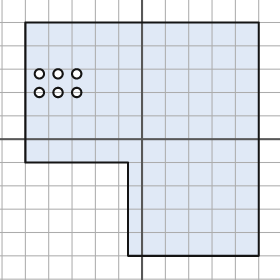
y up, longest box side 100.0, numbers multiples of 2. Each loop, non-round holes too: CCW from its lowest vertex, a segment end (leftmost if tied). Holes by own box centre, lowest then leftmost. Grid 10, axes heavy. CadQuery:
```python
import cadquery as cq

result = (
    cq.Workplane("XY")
    .moveTo(-6.0, -50.0)
    .lineTo(50.0, -50.0)
    .lineTo(50.0, 50.0)
    .lineTo(-50.0, 50.0)
    .lineTo(-50.0, -10.0)
    .lineTo(-6.0, -10.0)
    .close()
    .moveTo(-44.0, 20.0)
    .circle(2.0)
    .moveTo(-36.0, 20.0)
    .circle(2.0)
    .moveTo(-28.0, 20.0)
    .circle(2.0)
    .moveTo(-44.0, 28.0)
    .circle(2.0)
    .moveTo(-36.0, 28.0)
    .circle(2.0)
    .moveTo(-28.0, 28.0)
    .circle(2.0)
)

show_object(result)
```